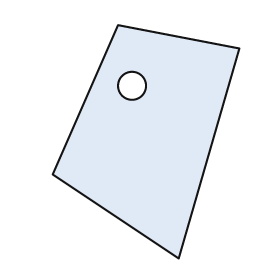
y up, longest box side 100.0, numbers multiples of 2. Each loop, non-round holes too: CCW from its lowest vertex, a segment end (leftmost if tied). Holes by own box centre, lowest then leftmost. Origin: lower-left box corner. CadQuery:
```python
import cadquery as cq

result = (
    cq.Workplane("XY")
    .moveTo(54.0, 0.0)
    .lineTo(80.0, 90.0)
    .lineTo(28.0, 100.0)
    .lineTo(0.0, 36.0)
    .close()
    .moveTo(34.0, 74.0)
    .circle(6.0)
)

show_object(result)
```